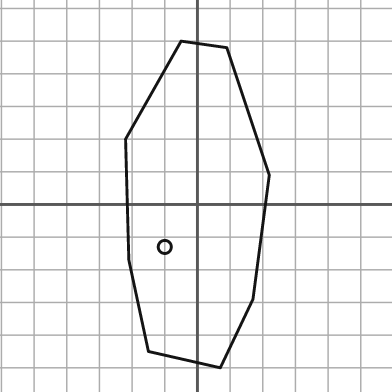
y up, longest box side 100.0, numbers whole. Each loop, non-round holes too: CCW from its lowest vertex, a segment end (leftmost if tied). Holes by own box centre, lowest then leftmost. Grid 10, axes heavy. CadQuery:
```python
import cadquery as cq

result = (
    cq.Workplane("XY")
    .moveTo(7.0, -50.0)
    .lineTo(17.0, -29.0)
    .lineTo(22.0, 9.0)
    .lineTo(9.0, 48.0)
    .lineTo(-5.0, 50.0)
    .lineTo(-22.0, 20.0)
    .lineTo(-21.0, -17.0)
    .lineTo(-15.0, -45.0)
    .close()
    .moveTo(-10.0, -13.0)
    .circle(2.0)
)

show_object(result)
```